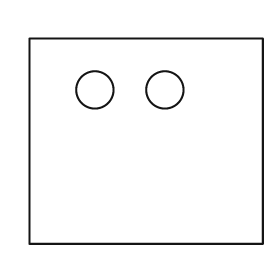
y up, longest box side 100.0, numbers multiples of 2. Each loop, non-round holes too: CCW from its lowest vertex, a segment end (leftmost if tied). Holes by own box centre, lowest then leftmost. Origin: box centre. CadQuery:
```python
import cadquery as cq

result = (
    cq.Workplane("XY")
    .moveTo(-50.0, -44.0)
    .lineTo(50.0, -44.0)
    .lineTo(50.0, 44.0)
    .lineTo(-50.0, 44.0)
    .close()
    .moveTo(-22.0, 22.0)
    .circle(8.0)
    .moveTo(8.0, 22.0)
    .circle(8.0)
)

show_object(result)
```